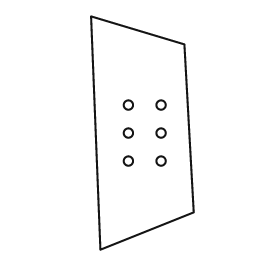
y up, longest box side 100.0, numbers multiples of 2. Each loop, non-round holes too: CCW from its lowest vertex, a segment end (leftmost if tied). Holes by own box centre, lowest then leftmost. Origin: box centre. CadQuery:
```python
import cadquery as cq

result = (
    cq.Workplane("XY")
    .moveTo(-18.0, -50.0)
    .lineTo(22.0, -34.0)
    .lineTo(18.0, 38.0)
    .lineTo(-22.0, 50.0)
    .close()
    .moveTo(-6.0, -12.0)
    .circle(2.0)
    .moveTo(8.0, -12.0)
    .circle(2.0)
    .moveTo(-6.0, 0.0)
    .circle(2.0)
    .moveTo(8.0, 0.0)
    .circle(2.0)
    .moveTo(-6.0, 12.0)
    .circle(2.0)
    .moveTo(8.0, 12.0)
    .circle(2.0)
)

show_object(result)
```